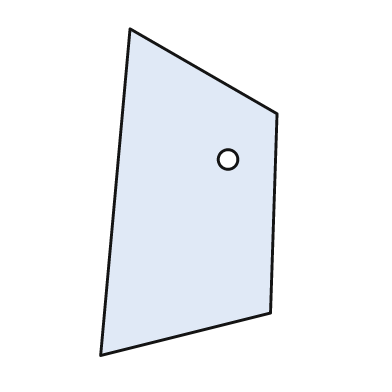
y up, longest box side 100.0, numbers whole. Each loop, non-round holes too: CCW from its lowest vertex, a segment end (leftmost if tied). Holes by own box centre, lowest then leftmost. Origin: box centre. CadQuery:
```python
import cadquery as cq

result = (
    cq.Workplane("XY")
    .moveTo(-27.0, -50.0)
    .lineTo(25.0, -37.0)
    .lineTo(27.0, 24.0)
    .lineTo(-18.0, 50.0)
    .close()
    .moveTo(12.0, 10.0)
    .circle(3.0)
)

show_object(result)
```